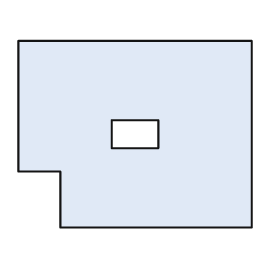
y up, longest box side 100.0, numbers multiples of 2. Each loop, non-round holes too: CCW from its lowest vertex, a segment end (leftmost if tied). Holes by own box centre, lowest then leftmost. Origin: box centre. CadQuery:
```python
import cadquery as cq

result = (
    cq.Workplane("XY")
    .moveTo(-32.0, -40.0)
    .lineTo(50.0, -40.0)
    .lineTo(50.0, 40.0)
    .lineTo(-50.0, 40.0)
    .lineTo(-50.0, -16.0)
    .lineTo(-32.0, -16.0)
    .close()
    .moveTo(-10.0, -6.0)
    .lineTo(10.0, -6.0)
    .lineTo(10.0, 6.0)
    .lineTo(-10.0, 6.0)
    .close()
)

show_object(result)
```